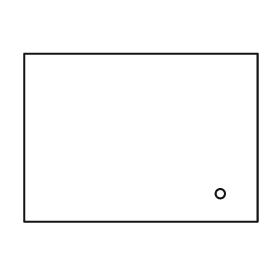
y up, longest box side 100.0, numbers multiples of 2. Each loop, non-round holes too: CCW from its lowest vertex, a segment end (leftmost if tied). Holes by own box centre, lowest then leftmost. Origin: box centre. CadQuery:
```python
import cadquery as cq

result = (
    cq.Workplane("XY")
    .moveTo(-50.0, -36.0)
    .lineTo(50.0, -36.0)
    .lineTo(50.0, 36.0)
    .lineTo(-50.0, 36.0)
    .close()
    .moveTo(34.0, -24.0)
    .circle(2.0)
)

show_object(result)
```